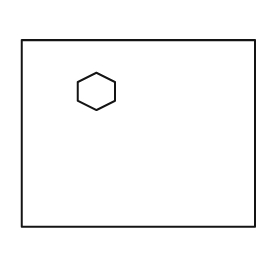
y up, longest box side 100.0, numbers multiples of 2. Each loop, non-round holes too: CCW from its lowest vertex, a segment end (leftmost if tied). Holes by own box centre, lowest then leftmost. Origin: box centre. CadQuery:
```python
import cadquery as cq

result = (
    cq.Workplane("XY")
    .moveTo(-50.0, -40.0)
    .lineTo(50.0, -40.0)
    .lineTo(50.0, 40.0)
    .lineTo(-50.0, 40.0)
    .close()
    .moveTo(-18.0, 10.0)
    .lineTo(-10.0, 14.0)
    .lineTo(-10.0, 22.0)
    .lineTo(-18.0, 26.0)
    .lineTo(-26.0, 22.0)
    .lineTo(-26.0, 14.0)
    .close()
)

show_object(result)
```